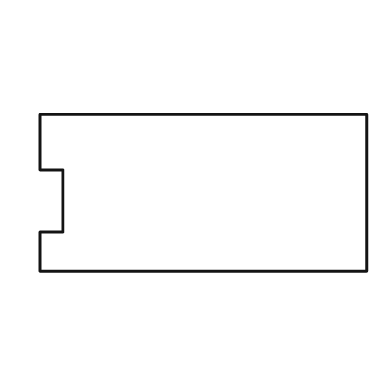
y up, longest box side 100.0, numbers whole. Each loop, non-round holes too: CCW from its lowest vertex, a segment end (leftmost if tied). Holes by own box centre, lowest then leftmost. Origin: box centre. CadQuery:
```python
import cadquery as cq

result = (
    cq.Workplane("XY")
    .moveTo(-50.0, -24.0)
    .lineTo(50.0, -24.0)
    .lineTo(50.0, 24.0)
    .lineTo(-50.0, 24.0)
    .lineTo(-50.0, 7.0)
    .lineTo(-43.0, 7.0)
    .lineTo(-43.0, -12.0)
    .lineTo(-50.0, -12.0)
    .close()
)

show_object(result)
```